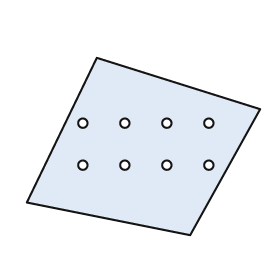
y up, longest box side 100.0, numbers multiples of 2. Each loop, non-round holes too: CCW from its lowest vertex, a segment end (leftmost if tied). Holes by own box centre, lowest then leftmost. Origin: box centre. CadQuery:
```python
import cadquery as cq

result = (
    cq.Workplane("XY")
    .moveTo(20.0, -38.0)
    .lineTo(50.0, 16.0)
    .lineTo(-20.0, 38.0)
    .lineTo(-50.0, -24.0)
    .close()
    .moveTo(-26.0, -8.0)
    .circle(2.0)
    .moveTo(-8.0, -8.0)
    .circle(2.0)
    .moveTo(10.0, -8.0)
    .circle(2.0)
    .moveTo(28.0, -8.0)
    .circle(2.0)
    .moveTo(-26.0, 10.0)
    .circle(2.0)
    .moveTo(-8.0, 10.0)
    .circle(2.0)
    .moveTo(10.0, 10.0)
    .circle(2.0)
    .moveTo(28.0, 10.0)
    .circle(2.0)
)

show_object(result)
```